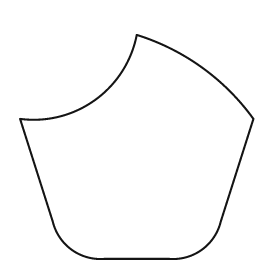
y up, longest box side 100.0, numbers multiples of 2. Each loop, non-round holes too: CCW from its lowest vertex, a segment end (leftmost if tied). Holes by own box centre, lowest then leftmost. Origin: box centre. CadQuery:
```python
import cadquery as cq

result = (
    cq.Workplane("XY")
    .moveTo(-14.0, -48.0)
    .lineTo(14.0, -48.0)
    .threePointArc((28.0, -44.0), (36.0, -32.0))
    .lineTo(50.0, 12.0)
    .threePointArc((28.0, 34.0), (0.0, 48.0))
    .threePointArc((-18.0, 20.0), (-50.0, 12.0))
    .lineTo(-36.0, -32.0)
    .threePointArc((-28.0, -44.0), (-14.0, -48.0))
    .close()
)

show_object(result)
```